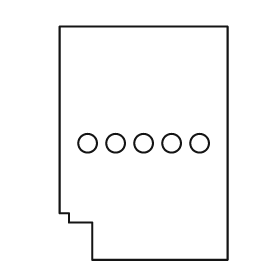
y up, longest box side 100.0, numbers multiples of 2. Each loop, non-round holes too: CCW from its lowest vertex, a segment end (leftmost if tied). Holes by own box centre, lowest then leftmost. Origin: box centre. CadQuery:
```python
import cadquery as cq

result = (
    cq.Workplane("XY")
    .moveTo(-22.0, -50.0)
    .lineTo(36.0, -50.0)
    .lineTo(36.0, 50.0)
    .lineTo(-36.0, 50.0)
    .lineTo(-36.0, -30.0)
    .lineTo(-32.0, -30.0)
    .lineTo(-32.0, -34.0)
    .lineTo(-22.0, -34.0)
    .close()
    .moveTo(-24.0, 0.0)
    .circle(4.0)
    .moveTo(-12.0, 0.0)
    .circle(4.0)
    .moveTo(0.0, 0.0)
    .circle(4.0)
    .moveTo(12.0, 0.0)
    .circle(4.0)
    .moveTo(24.0, 0.0)
    .circle(4.0)
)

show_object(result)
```